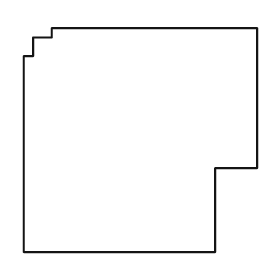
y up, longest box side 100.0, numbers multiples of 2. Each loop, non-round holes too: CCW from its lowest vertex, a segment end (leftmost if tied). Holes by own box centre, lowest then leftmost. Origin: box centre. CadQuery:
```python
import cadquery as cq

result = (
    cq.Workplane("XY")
    .moveTo(-50.0, -48.0)
    .lineTo(32.0, -48.0)
    .lineTo(32.0, -12.0)
    .lineTo(50.0, -12.0)
    .lineTo(50.0, 48.0)
    .lineTo(-38.0, 48.0)
    .lineTo(-38.0, 44.0)
    .lineTo(-46.0, 44.0)
    .lineTo(-46.0, 36.0)
    .lineTo(-50.0, 36.0)
    .close()
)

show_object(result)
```